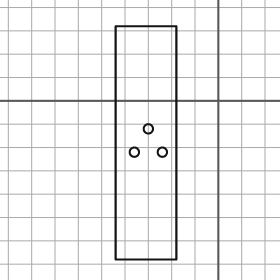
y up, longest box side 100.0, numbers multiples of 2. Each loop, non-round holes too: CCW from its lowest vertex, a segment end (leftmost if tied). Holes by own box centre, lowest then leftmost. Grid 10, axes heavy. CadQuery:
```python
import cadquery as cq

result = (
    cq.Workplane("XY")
    .moveTo(-44.0, -68.0)
    .lineTo(-18.0, -68.0)
    .lineTo(-18.0, 32.0)
    .lineTo(-44.0, 32.0)
    .close()
    .moveTo(-36.0, -22.0)
    .circle(2.0)
    .moveTo(-24.0, -22.0)
    .circle(2.0)
    .moveTo(-30.0, -12.0)
    .circle(2.0)
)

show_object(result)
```